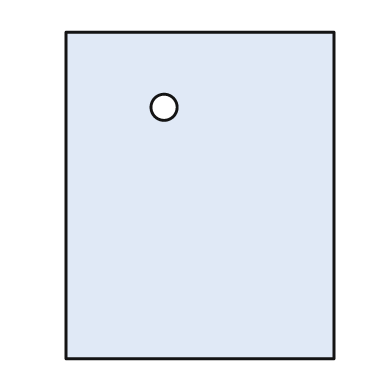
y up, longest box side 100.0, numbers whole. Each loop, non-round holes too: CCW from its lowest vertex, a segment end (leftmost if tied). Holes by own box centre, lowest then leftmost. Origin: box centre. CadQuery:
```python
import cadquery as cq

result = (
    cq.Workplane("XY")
    .moveTo(-41.0, -50.0)
    .lineTo(41.0, -50.0)
    .lineTo(41.0, 50.0)
    .lineTo(-41.0, 50.0)
    .close()
    .moveTo(-11.0, 27.0)
    .circle(4.0)
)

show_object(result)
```